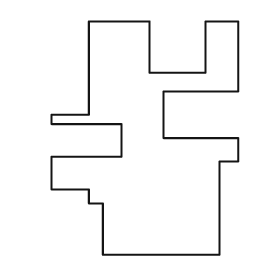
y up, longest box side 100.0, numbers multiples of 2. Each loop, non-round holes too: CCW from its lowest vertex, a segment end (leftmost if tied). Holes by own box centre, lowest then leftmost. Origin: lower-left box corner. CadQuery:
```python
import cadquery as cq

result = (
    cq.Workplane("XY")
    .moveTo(22.0, 0.0)
    .lineTo(72.0, 0.0)
    .lineTo(72.0, 40.0)
    .lineTo(80.0, 40.0)
    .lineTo(80.0, 50.0)
    .lineTo(48.0, 50.0)
    .lineTo(48.0, 70.0)
    .lineTo(80.0, 70.0)
    .lineTo(80.0, 100.0)
    .lineTo(66.0, 100.0)
    .lineTo(66.0, 78.0)
    .lineTo(42.0, 78.0)
    .lineTo(42.0, 100.0)
    .lineTo(16.0, 100.0)
    .lineTo(16.0, 60.0)
    .lineTo(0.0, 60.0)
    .lineTo(0.0, 56.0)
    .lineTo(30.0, 56.0)
    .lineTo(30.0, 42.0)
    .lineTo(0.0, 42.0)
    .lineTo(0.0, 28.0)
    .lineTo(16.0, 28.0)
    .lineTo(16.0, 22.0)
    .lineTo(22.0, 22.0)
    .close()
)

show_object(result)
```